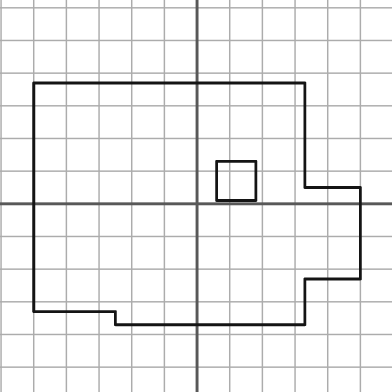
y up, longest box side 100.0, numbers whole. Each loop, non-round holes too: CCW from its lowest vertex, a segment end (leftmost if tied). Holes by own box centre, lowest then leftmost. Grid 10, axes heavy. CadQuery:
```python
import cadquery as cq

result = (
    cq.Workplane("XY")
    .moveTo(-25.0, -37.0)
    .lineTo(33.0, -37.0)
    .lineTo(33.0, -23.0)
    .lineTo(50.0, -23.0)
    .lineTo(50.0, 5.0)
    .lineTo(33.0, 5.0)
    .lineTo(33.0, 37.0)
    .lineTo(-50.0, 37.0)
    .lineTo(-50.0, -33.0)
    .lineTo(-25.0, -33.0)
    .close()
    .moveTo(6.0, 1.0)
    .lineTo(18.0, 1.0)
    .lineTo(18.0, 13.0)
    .lineTo(6.0, 13.0)
    .close()
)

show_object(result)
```